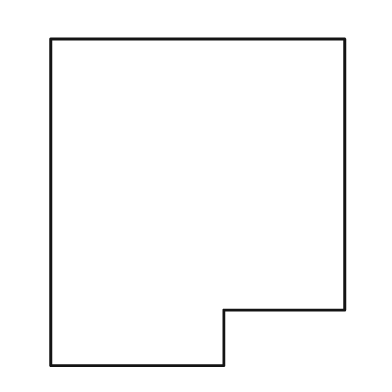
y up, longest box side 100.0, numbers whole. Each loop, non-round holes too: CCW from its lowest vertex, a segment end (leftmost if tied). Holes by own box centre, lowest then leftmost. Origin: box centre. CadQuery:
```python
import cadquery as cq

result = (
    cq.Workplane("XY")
    .moveTo(-45.0, -50.0)
    .lineTo(8.0, -50.0)
    .lineTo(8.0, -33.0)
    .lineTo(45.0, -33.0)
    .lineTo(45.0, 50.0)
    .lineTo(-45.0, 50.0)
    .close()
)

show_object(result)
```